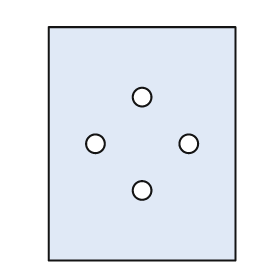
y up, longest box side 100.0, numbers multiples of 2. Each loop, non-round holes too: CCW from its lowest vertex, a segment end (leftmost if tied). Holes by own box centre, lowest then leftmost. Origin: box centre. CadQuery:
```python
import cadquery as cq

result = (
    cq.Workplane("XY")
    .moveTo(-40.0, -50.0)
    .lineTo(40.0, -50.0)
    .lineTo(40.0, 50.0)
    .lineTo(-40.0, 50.0)
    .close()
    .moveTo(0.0, -20.0)
    .circle(4.0)
    .moveTo(-20.0, 0.0)
    .circle(4.0)
    .moveTo(20.0, 0.0)
    .circle(4.0)
    .moveTo(0.0, 20.0)
    .circle(4.0)
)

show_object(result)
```